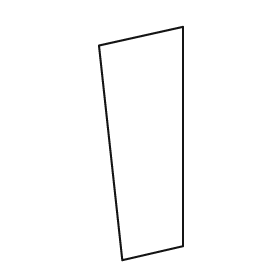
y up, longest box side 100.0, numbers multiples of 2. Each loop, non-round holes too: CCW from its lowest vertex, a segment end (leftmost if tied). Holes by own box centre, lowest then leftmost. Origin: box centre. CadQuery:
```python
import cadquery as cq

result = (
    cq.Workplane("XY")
    .moveTo(-8.0, -50.0)
    .lineTo(18.0, -44.0)
    .lineTo(18.0, 50.0)
    .lineTo(-18.0, 42.0)
    .close()
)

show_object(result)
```